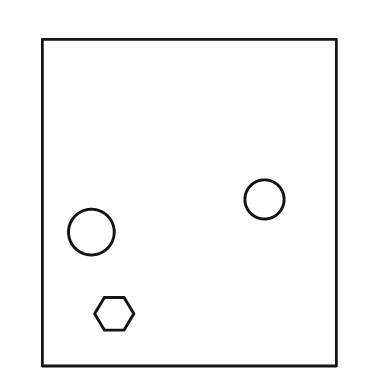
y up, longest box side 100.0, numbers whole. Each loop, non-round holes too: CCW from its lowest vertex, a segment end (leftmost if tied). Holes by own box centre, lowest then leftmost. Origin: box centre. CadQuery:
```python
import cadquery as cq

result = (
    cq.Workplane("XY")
    .moveTo(-45.0, -50.0)
    .lineTo(45.0, -50.0)
    .lineTo(45.0, 50.0)
    .lineTo(-45.0, 50.0)
    .close()
    .moveTo(-26.0, -39.0)
    .lineTo(-20.0, -39.0)
    .lineTo(-17.0, -34.0)
    .lineTo(-20.0, -29.0)
    .lineTo(-26.0, -29.0)
    .lineTo(-29.0, -34.0)
    .close()
    .moveTo(-30.0, -9.0)
    .circle(7.0)
    .moveTo(23.0, 1.0)
    .circle(6.0)
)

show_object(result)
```